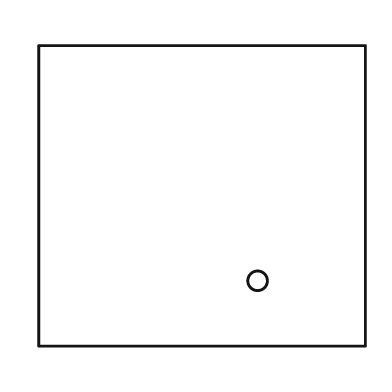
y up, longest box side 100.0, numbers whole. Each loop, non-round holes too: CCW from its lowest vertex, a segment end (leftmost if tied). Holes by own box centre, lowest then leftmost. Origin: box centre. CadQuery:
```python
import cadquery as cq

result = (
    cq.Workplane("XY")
    .moveTo(-50.0, -46.0)
    .lineTo(50.0, -46.0)
    .lineTo(50.0, 46.0)
    .lineTo(-50.0, 46.0)
    .close()
    .moveTo(17.0, -26.0)
    .circle(3.0)
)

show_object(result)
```